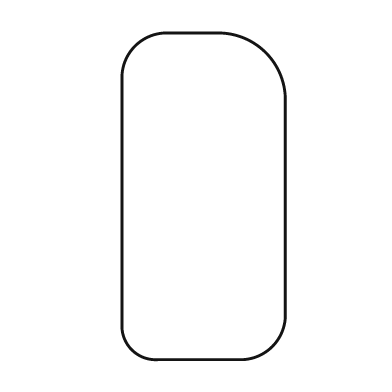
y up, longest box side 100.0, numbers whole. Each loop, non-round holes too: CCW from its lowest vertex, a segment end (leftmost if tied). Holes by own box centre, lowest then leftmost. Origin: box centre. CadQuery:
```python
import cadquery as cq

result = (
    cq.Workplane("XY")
    .moveTo(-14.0, -50.0)
    .lineTo(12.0, -50.0)
    .threePointArc((21.0, -46.0), (25.0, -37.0))
    .lineTo(25.0, 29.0)
    .threePointArc((19.0, 44.0), (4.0, 50.0))
    .lineTo(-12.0, 50.0)
    .threePointArc((-21.0, 46.0), (-25.0, 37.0))
    .lineTo(-25.0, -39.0)
    .threePointArc((-22.0, -47.0), (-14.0, -50.0))
    .close()
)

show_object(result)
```